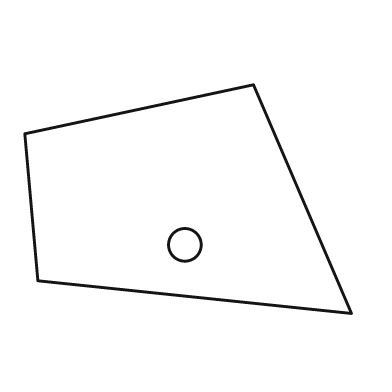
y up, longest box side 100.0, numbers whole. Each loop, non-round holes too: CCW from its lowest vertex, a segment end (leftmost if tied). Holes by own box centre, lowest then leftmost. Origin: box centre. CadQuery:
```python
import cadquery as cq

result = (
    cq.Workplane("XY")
    .moveTo(50.0, -35.0)
    .lineTo(20.0, 35.0)
    .lineTo(-50.0, 20.0)
    .lineTo(-46.0, -25.0)
    .close()
    .moveTo(-1.0, -14.0)
    .circle(5.0)
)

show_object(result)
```